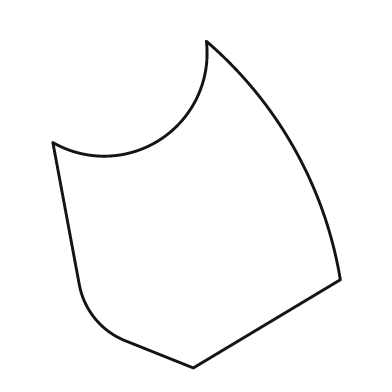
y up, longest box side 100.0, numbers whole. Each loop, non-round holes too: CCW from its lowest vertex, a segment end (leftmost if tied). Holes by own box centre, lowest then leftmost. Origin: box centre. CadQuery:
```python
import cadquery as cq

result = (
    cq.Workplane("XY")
    .moveTo(-1.0, -50.0)
    .lineTo(44.0, -23.0)
    .threePointArc((30.0, 17.0), (3.0, 50.0))
    .threePointArc((-11.0, 20.0), (-44.0, 19.0))
    .lineTo(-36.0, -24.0)
    .threePointArc((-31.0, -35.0), (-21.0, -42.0))
    .close()
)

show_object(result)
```